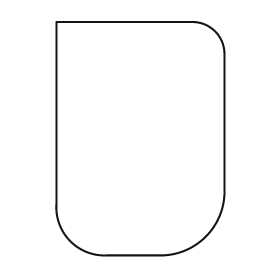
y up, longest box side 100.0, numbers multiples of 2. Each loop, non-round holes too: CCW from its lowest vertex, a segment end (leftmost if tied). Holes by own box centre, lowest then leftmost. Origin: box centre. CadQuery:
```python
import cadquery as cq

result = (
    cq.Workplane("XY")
    .moveTo(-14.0, -50.0)
    .lineTo(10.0, -50.0)
    .threePointArc((28.0, -42.0), (36.0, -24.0))
    .lineTo(36.0, 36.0)
    .threePointArc((32.0, 46.0), (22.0, 50.0))
    .lineTo(-36.0, 50.0)
    .lineTo(-36.0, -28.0)
    .threePointArc((-30.0, -44.0), (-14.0, -50.0))
    .close()
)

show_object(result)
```